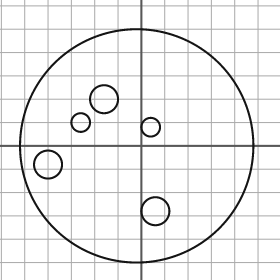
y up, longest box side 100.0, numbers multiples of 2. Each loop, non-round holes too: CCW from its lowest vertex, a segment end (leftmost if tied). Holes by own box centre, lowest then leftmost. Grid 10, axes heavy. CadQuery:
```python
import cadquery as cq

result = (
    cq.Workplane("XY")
    .moveTo(-2.0, 0.0)
    .circle(50.0)
    .moveTo(6.0, -28.0)
    .circle(6.0)
    .moveTo(-40.0, -8.0)
    .circle(6.0)
    .moveTo(4.0, 8.0)
    .circle(4.0)
    .moveTo(-26.0, 10.0)
    .circle(4.0)
    .moveTo(-16.0, 20.0)
    .circle(6.0)
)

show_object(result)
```